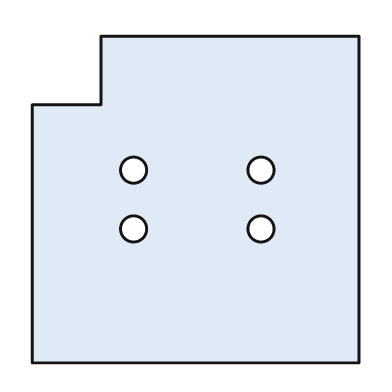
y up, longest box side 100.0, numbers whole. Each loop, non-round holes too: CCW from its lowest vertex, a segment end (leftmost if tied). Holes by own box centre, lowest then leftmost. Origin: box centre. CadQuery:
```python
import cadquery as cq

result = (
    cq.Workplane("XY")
    .moveTo(-50.0, -50.0)
    .lineTo(50.0, -50.0)
    .lineTo(50.0, 50.0)
    .lineTo(-29.0, 50.0)
    .lineTo(-29.0, 29.0)
    .lineTo(-50.0, 29.0)
    .close()
    .moveTo(-19.0, -9.0)
    .circle(4.0)
    .moveTo(20.0, -9.0)
    .circle(4.0)
    .moveTo(-19.0, 9.0)
    .circle(4.0)
    .moveTo(20.0, 9.0)
    .circle(4.0)
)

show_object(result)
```